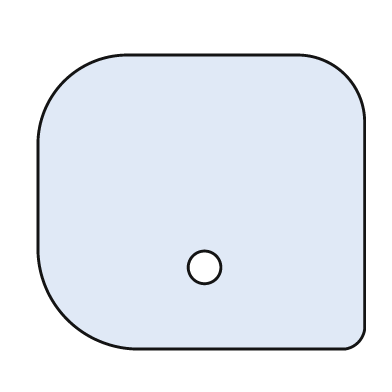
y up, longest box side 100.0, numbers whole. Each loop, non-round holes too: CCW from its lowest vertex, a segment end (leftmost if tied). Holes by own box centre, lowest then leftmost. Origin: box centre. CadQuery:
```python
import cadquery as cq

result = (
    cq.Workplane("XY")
    .moveTo(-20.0, -45.0)
    .lineTo(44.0, -45.0)
    .threePointArc((48.0, -43.0), (50.0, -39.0))
    .lineTo(50.0, 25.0)
    .threePointArc((44.0, 39.0), (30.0, 45.0))
    .lineTo(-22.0, 45.0)
    .threePointArc((-42.0, 37.0), (-50.0, 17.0))
    .lineTo(-50.0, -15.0)
    .threePointArc((-41.0, -36.0), (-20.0, -45.0))
    .close()
    .moveTo(1.0, -20.0)
    .circle(5.0)
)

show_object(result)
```